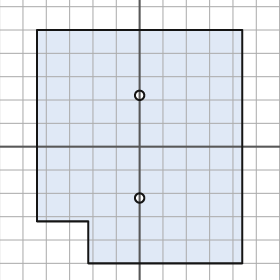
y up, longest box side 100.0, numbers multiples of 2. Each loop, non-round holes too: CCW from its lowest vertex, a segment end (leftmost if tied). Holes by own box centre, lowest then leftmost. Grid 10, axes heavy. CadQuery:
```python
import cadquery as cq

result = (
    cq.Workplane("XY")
    .moveTo(-22.0, -50.0)
    .lineTo(44.0, -50.0)
    .lineTo(44.0, 50.0)
    .lineTo(-44.0, 50.0)
    .lineTo(-44.0, -32.0)
    .lineTo(-22.0, -32.0)
    .close()
    .moveTo(0.0, -22.0)
    .circle(2.0)
    .moveTo(0.0, 22.0)
    .circle(2.0)
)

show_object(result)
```